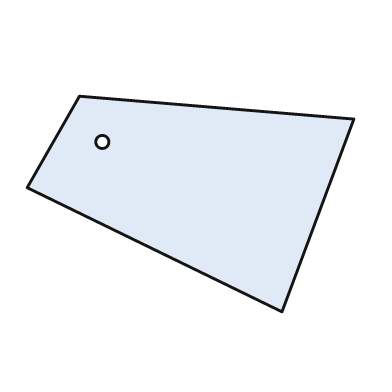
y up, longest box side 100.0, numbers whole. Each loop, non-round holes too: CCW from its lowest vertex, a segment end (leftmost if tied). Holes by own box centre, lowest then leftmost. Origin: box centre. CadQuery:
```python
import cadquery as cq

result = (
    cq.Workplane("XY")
    .moveTo(28.0, -33.0)
    .lineTo(50.0, 26.0)
    .lineTo(-34.0, 33.0)
    .lineTo(-50.0, 5.0)
    .close()
    .moveTo(-27.0, 19.0)
    .circle(2.0)
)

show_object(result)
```